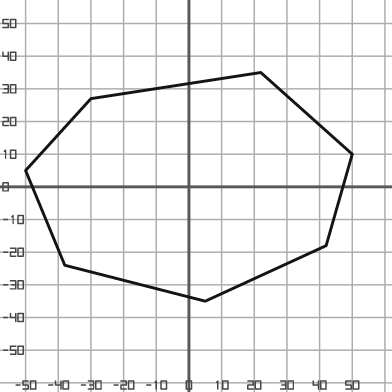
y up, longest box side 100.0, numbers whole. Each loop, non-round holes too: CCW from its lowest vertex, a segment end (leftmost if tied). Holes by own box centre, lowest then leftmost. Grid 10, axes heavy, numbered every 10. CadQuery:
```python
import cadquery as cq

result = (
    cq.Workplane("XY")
    .moveTo(5.0, -35.0)
    .lineTo(42.0, -18.0)
    .lineTo(50.0, 10.0)
    .lineTo(22.0, 35.0)
    .lineTo(-30.0, 27.0)
    .lineTo(-50.0, 5.0)
    .lineTo(-38.0, -24.0)
    .close()
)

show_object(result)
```